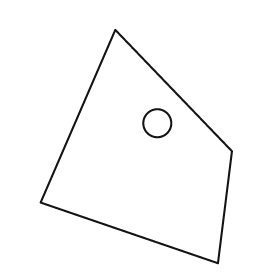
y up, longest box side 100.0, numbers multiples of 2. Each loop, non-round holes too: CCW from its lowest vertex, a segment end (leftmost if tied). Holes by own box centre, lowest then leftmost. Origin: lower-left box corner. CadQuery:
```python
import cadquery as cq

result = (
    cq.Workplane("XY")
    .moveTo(76.0, 0.0)
    .lineTo(82.0, 48.0)
    .lineTo(32.0, 100.0)
    .lineTo(0.0, 26.0)
    .close()
    .moveTo(50.0, 60.0)
    .circle(6.0)
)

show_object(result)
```